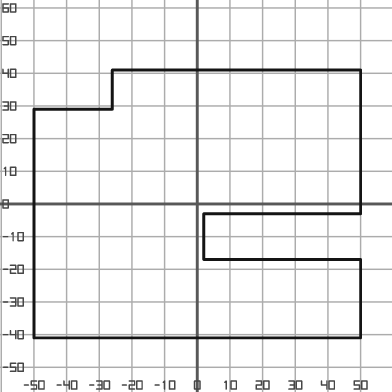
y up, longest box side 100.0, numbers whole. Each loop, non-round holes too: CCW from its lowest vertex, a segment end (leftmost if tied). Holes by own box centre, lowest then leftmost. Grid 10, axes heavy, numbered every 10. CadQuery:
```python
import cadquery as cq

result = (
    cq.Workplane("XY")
    .moveTo(-50.0, -41.0)
    .lineTo(50.0, -41.0)
    .lineTo(50.0, -17.0)
    .lineTo(2.0, -17.0)
    .lineTo(2.0, -3.0)
    .lineTo(50.0, -3.0)
    .lineTo(50.0, 41.0)
    .lineTo(-26.0, 41.0)
    .lineTo(-26.0, 29.0)
    .lineTo(-50.0, 29.0)
    .close()
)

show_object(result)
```